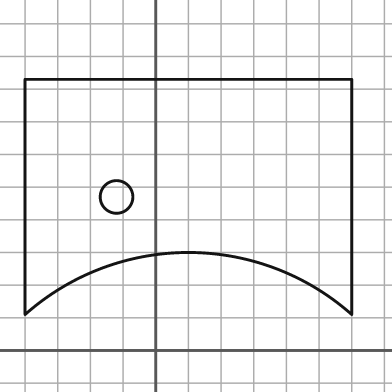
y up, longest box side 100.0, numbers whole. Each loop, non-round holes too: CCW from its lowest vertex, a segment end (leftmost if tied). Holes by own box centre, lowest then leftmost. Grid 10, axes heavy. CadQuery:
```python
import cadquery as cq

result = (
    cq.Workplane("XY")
    .moveTo(-40.0, 11.0)
    .threePointArc((10.0, 30.0), (60.0, 11.0))
    .lineTo(60.0, 83.0)
    .lineTo(-40.0, 83.0)
    .close()
    .moveTo(-12.0, 47.0)
    .circle(5.0)
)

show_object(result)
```